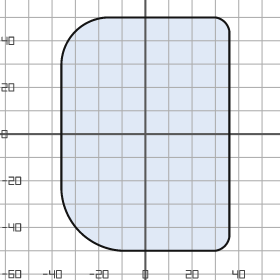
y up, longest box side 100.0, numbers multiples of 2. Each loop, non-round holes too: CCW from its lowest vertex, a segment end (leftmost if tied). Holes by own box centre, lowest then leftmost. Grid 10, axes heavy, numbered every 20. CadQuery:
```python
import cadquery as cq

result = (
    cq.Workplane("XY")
    .moveTo(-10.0, -50.0)
    .lineTo(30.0, -50.0)
    .threePointArc((34.0, -48.0), (36.0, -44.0))
    .lineTo(36.0, 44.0)
    .threePointArc((34.0, 48.0), (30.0, 50.0))
    .lineTo(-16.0, 50.0)
    .threePointArc((-30.0, 44.0), (-36.0, 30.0))
    .lineTo(-36.0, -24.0)
    .threePointArc((-28.0, -42.0), (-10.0, -50.0))
    .close()
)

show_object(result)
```